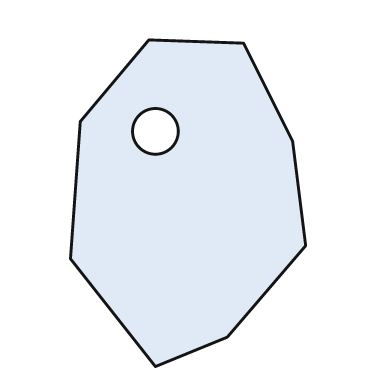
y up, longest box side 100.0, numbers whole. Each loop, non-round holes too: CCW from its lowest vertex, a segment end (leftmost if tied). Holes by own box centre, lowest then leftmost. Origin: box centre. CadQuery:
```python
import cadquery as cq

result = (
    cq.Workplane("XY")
    .moveTo(-10.0, -50.0)
    .lineTo(12.0, -41.0)
    .lineTo(36.0, -13.0)
    .lineTo(32.0, 19.0)
    .lineTo(17.0, 49.0)
    .lineTo(-12.0, 50.0)
    .lineTo(-33.0, 25.0)
    .lineTo(-36.0, -17.0)
    .close()
    .moveTo(-10.0, 22.0)
    .circle(7.0)
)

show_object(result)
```